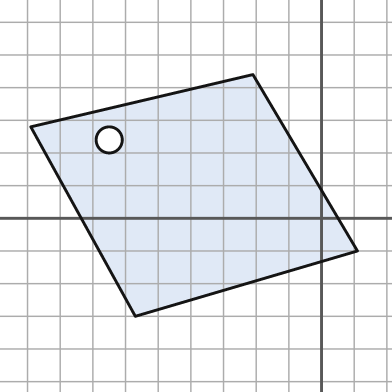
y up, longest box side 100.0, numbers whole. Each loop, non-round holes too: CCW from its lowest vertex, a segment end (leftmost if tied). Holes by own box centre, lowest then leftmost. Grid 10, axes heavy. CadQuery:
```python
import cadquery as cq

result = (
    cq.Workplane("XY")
    .moveTo(-57.0, -30.0)
    .lineTo(11.0, -10.0)
    .lineTo(-21.0, 44.0)
    .lineTo(-89.0, 28.0)
    .close()
    .moveTo(-65.0, 24.0)
    .circle(4.0)
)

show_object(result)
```